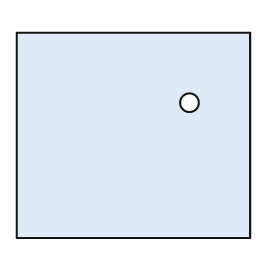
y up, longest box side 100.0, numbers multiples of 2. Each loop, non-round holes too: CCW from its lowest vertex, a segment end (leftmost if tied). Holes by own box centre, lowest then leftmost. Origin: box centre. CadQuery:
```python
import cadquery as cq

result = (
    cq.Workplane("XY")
    .moveTo(-50.0, -44.0)
    .lineTo(50.0, -44.0)
    .lineTo(50.0, 44.0)
    .lineTo(-50.0, 44.0)
    .close()
    .moveTo(24.0, 14.0)
    .circle(4.0)
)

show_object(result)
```